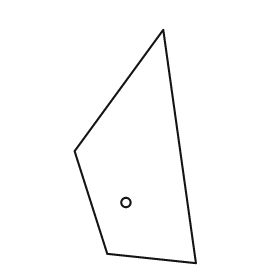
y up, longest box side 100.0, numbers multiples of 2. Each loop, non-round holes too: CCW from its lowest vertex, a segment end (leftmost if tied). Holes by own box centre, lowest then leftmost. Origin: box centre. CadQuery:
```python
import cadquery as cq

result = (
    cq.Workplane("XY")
    .moveTo(26.0, -50.0)
    .lineTo(12.0, 50.0)
    .lineTo(-26.0, -2.0)
    .lineTo(-12.0, -46.0)
    .close()
    .moveTo(-4.0, -24.0)
    .circle(2.0)
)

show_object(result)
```